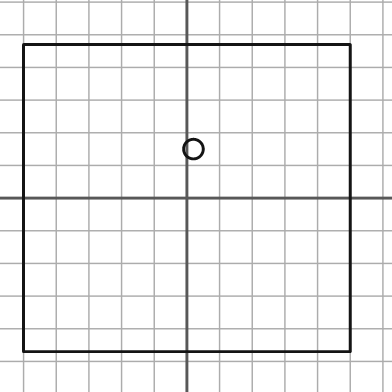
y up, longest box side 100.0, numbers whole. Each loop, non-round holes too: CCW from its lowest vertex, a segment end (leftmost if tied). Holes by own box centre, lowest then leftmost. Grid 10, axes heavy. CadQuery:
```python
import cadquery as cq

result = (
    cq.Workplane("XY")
    .moveTo(-50.0, -47.0)
    .lineTo(50.0, -47.0)
    .lineTo(50.0, 47.0)
    .lineTo(-50.0, 47.0)
    .close()
    .moveTo(2.0, 15.0)
    .circle(3.0)
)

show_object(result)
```